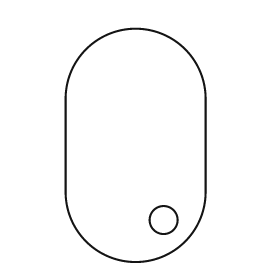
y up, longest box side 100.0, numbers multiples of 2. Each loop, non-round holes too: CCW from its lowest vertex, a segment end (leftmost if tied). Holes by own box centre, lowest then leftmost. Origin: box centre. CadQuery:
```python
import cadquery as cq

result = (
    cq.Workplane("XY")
    .moveTo(-30.0, -20.0)
    .threePointArc((0.0, -50.0), (30.0, -20.0))
    .lineTo(30.0, 20.0)
    .threePointArc((0.0, 50.0), (-30.0, 20.0))
    .close()
    .moveTo(12.0, -32.0)
    .circle(6.0)
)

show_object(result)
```